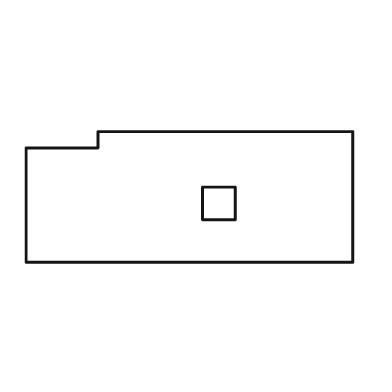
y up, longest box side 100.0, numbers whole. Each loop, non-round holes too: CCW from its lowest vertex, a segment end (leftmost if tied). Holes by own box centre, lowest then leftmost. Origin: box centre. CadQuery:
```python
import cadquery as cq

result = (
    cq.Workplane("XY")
    .moveTo(-50.0, -20.0)
    .lineTo(50.0, -20.0)
    .lineTo(50.0, 20.0)
    .lineTo(-28.0, 20.0)
    .lineTo(-28.0, 15.0)
    .lineTo(-50.0, 15.0)
    .close()
    .moveTo(4.0, -7.0)
    .lineTo(14.0, -7.0)
    .lineTo(14.0, 3.0)
    .lineTo(4.0, 3.0)
    .close()
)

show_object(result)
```